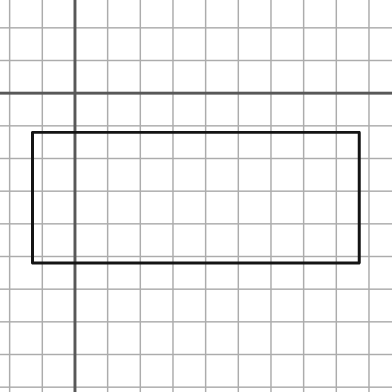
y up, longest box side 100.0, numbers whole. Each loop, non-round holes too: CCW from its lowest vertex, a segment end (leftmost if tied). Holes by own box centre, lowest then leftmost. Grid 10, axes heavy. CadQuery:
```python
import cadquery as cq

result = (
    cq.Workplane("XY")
    .moveTo(-13.0, -52.0)
    .lineTo(87.0, -52.0)
    .lineTo(87.0, -12.0)
    .lineTo(-13.0, -12.0)
    .close()
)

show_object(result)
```